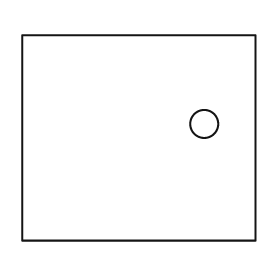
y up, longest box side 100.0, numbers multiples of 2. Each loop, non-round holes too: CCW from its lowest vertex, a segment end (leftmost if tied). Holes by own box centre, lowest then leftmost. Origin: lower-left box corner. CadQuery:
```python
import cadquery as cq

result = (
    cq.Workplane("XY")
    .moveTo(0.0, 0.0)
    .lineTo(100.0, 0.0)
    .lineTo(100.0, 88.0)
    .lineTo(0.0, 88.0)
    .close()
    .moveTo(78.0, 50.0)
    .circle(6.0)
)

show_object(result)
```